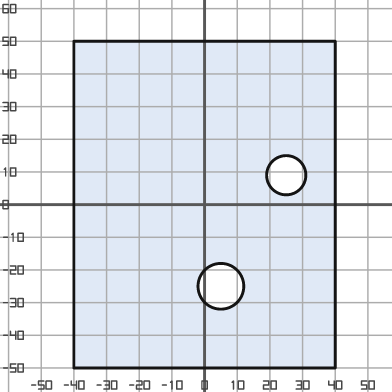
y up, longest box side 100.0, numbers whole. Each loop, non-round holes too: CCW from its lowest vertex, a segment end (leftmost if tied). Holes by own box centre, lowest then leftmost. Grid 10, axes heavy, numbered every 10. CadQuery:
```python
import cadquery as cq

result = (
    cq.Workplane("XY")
    .moveTo(-40.0, -50.0)
    .lineTo(40.0, -50.0)
    .lineTo(40.0, 50.0)
    .lineTo(-40.0, 50.0)
    .close()
    .moveTo(5.0, -25.0)
    .circle(7.0)
    .moveTo(25.0, 9.0)
    .circle(6.0)
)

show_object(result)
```